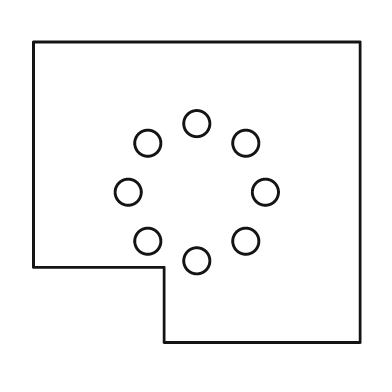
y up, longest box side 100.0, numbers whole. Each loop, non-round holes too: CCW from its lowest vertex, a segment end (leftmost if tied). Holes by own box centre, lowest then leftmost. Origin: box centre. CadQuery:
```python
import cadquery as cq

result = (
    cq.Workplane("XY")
    .moveTo(-10.0, -46.0)
    .lineTo(50.0, -46.0)
    .lineTo(50.0, 46.0)
    .lineTo(-50.0, 46.0)
    .lineTo(-50.0, -23.0)
    .lineTo(-10.0, -23.0)
    .close()
    .moveTo(0.0, -21.0)
    .circle(4.0)
    .moveTo(-15.0, -15.0)
    .circle(4.0)
    .moveTo(15.0, -15.0)
    .circle(4.0)
    .moveTo(-21.0, 0.0)
    .circle(4.0)
    .moveTo(21.0, 0.0)
    .circle(4.0)
    .moveTo(-15.0, 15.0)
    .circle(4.0)
    .moveTo(15.0, 15.0)
    .circle(4.0)
    .moveTo(0.0, 21.0)
    .circle(4.0)
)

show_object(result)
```